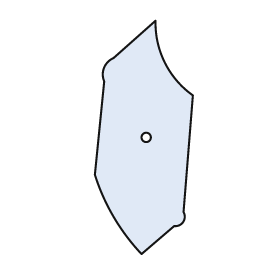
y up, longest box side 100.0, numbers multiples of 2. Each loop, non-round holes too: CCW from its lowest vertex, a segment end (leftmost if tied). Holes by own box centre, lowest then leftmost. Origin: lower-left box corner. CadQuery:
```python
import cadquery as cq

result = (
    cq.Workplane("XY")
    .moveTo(20.0, 0.0)
    .lineTo(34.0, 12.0)
    .threePointArc((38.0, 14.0), (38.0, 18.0))
    .lineTo(42.0, 68.0)
    .threePointArc((30.0, 82.0), (26.0, 100.0))
    .lineTo(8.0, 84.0)
    .threePointArc((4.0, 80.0), (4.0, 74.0))
    .lineTo(0.0, 34.0)
    .threePointArc((8.0, 16.0), (20.0, 0.0))
    .close()
    .moveTo(22.0, 50.0)
    .circle(2.0)
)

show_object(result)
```